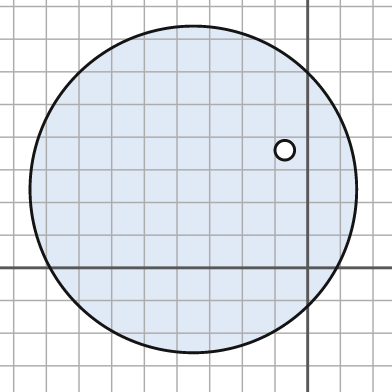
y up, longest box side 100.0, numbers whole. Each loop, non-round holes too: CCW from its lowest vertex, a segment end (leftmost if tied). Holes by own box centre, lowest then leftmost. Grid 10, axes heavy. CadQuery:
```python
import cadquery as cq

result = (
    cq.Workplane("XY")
    .moveTo(-35.0, 24.0)
    .circle(50.0)
    .moveTo(-7.0, 36.0)
    .circle(3.0)
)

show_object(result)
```